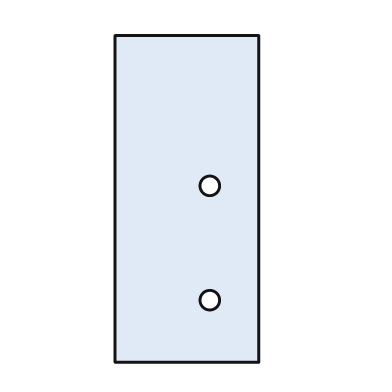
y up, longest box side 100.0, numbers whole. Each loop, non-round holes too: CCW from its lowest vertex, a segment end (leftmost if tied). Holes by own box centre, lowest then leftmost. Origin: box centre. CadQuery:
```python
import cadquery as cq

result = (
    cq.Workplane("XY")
    .moveTo(-22.0, -50.0)
    .lineTo(22.0, -50.0)
    .lineTo(22.0, 50.0)
    .lineTo(-22.0, 50.0)
    .close()
    .moveTo(7.0, -31.0)
    .circle(3.0)
    .moveTo(7.0, 4.0)
    .circle(3.0)
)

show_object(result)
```